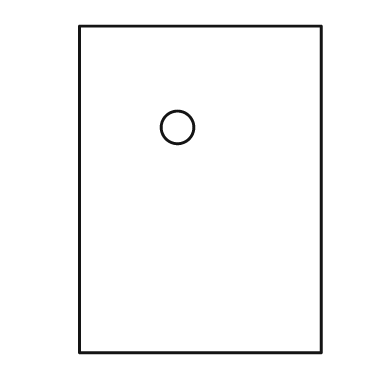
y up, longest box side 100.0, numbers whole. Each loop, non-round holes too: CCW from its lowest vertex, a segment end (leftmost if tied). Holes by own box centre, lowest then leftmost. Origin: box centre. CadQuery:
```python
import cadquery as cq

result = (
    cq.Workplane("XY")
    .moveTo(-37.0, -50.0)
    .lineTo(37.0, -50.0)
    .lineTo(37.0, 50.0)
    .lineTo(-37.0, 50.0)
    .close()
    .moveTo(-7.0, 19.0)
    .circle(5.0)
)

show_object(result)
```